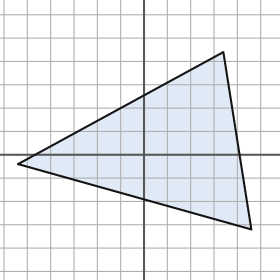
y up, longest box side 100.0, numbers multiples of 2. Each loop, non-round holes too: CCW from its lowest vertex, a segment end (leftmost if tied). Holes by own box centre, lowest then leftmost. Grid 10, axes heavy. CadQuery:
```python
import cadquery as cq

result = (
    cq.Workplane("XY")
    .moveTo(46.0, -32.0)
    .lineTo(34.0, 44.0)
    .lineTo(-54.0, -4.0)
    .close()
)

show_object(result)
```